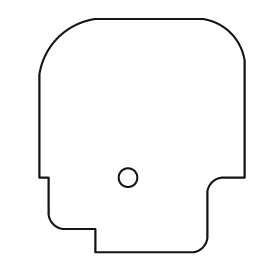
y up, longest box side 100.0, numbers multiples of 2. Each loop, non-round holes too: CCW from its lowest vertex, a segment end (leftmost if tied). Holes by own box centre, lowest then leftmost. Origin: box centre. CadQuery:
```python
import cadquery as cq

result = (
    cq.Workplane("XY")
    .moveTo(-20.0, -50.0)
    .lineTo(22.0, -50.0)
    .threePointArc((26.0, -48.0), (28.0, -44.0))
    .lineTo(28.0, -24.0)
    .threePointArc((30.0, -20.0), (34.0, -18.0))
    .lineTo(44.0, -18.0)
    .lineTo(44.0, 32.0)
    .threePointArc((38.0, 44.0), (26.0, 50.0))
    .lineTo(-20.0, 50.0)
    .threePointArc((-36.0, 42.0), (-44.0, 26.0))
    .lineTo(-44.0, -18.0)
    .lineTo(-40.0, -18.0)
    .lineTo(-40.0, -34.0)
    .threePointArc((-38.0, -38.0), (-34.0, -40.0))
    .lineTo(-20.0, -40.0)
    .close()
    .moveTo(-6.0, -18.0)
    .circle(4.0)
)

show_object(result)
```